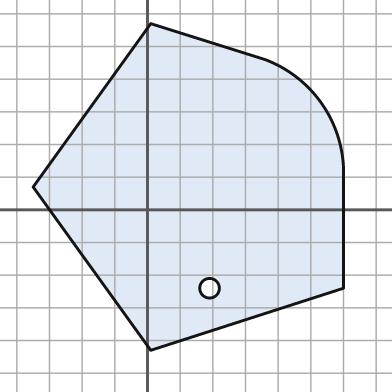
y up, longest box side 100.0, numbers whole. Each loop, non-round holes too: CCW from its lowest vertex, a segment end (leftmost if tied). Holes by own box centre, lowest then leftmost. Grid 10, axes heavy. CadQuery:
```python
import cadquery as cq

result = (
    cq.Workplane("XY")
    .moveTo(1.0, -43.0)
    .lineTo(60.0, -24.0)
    .lineTo(60.0, 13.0)
    .threePointArc((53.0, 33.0), (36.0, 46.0))
    .lineTo(1.0, 57.0)
    .lineTo(-35.0, 7.0)
    .close()
    .moveTo(19.0, -24.0)
    .circle(3.0)
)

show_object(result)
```